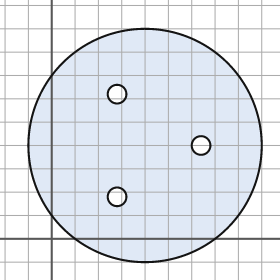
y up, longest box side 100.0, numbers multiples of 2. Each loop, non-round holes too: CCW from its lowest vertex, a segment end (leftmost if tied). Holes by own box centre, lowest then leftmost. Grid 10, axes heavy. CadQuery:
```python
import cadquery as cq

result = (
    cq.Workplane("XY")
    .moveTo(40.0, 40.0)
    .circle(50.0)
    .moveTo(28.0, 18.0)
    .circle(4.0)
    .moveTo(64.0, 40.0)
    .circle(4.0)
    .moveTo(28.0, 62.0)
    .circle(4.0)
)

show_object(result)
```